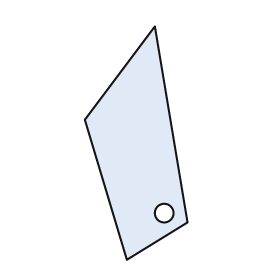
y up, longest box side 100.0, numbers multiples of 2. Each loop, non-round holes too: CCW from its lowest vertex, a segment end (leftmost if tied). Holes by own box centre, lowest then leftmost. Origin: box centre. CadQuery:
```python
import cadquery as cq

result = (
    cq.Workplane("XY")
    .moveTo(-4.0, -50.0)
    .lineTo(22.0, -34.0)
    .lineTo(8.0, 50.0)
    .lineTo(-22.0, 10.0)
    .close()
    .moveTo(12.0, -30.0)
    .circle(4.0)
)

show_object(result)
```